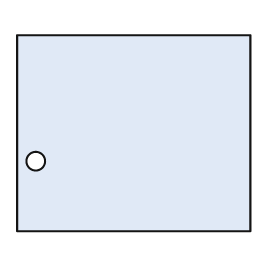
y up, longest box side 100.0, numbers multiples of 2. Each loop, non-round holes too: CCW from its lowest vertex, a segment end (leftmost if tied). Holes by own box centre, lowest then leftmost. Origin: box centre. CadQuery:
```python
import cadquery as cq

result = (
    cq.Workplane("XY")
    .moveTo(-50.0, -42.0)
    .lineTo(50.0, -42.0)
    .lineTo(50.0, 42.0)
    .lineTo(-50.0, 42.0)
    .close()
    .moveTo(-42.0, -12.0)
    .circle(4.0)
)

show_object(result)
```